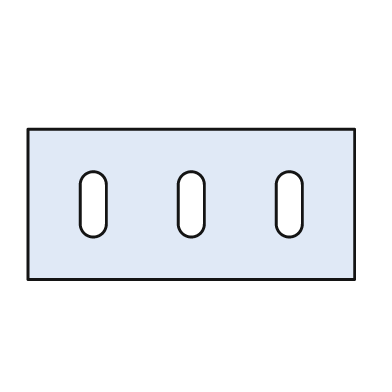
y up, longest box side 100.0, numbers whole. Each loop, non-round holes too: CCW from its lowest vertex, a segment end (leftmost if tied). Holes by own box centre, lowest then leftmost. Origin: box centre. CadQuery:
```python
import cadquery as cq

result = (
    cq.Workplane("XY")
    .moveTo(-50.0, -23.0)
    .lineTo(50.0, -23.0)
    .lineTo(50.0, 23.0)
    .lineTo(-50.0, 23.0)
    .close()
    .moveTo(-34.0, -6.0)
    .threePointArc((-30.0, -10.0), (-26.0, -6.0))
    .lineTo(-26.0, 6.0)
    .threePointArc((-30.0, 10.0), (-34.0, 6.0))
    .close()
    .moveTo(-4.0, -6.0)
    .threePointArc((0.0, -10.0), (4.0, -6.0))
    .lineTo(4.0, 6.0)
    .threePointArc((0.0, 10.0), (-4.0, 6.0))
    .close()
    .moveTo(26.0, -6.0)
    .threePointArc((30.0, -10.0), (34.0, -6.0))
    .lineTo(34.0, 6.0)
    .threePointArc((30.0, 10.0), (26.0, 6.0))
    .close()
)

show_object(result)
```